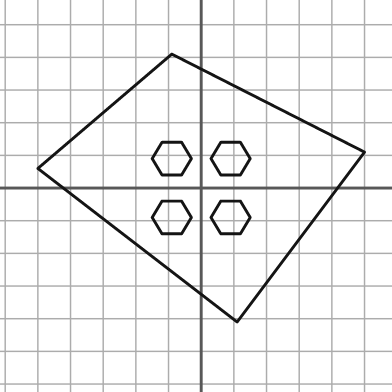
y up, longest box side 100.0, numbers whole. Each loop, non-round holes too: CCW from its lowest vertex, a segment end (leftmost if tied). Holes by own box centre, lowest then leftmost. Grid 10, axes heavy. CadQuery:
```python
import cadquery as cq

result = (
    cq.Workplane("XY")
    .moveTo(11.0, -41.0)
    .lineTo(50.0, 11.0)
    .lineTo(-9.0, 41.0)
    .lineTo(-50.0, 6.0)
    .close()
    .moveTo(-12.0, -14.0)
    .lineTo(-6.0, -14.0)
    .lineTo(-3.0, -9.0)
    .lineTo(-6.0, -4.0)
    .lineTo(-12.0, -4.0)
    .lineTo(-15.0, -9.0)
    .close()
    .moveTo(6.0, -14.0)
    .lineTo(12.0, -14.0)
    .lineTo(15.0, -9.0)
    .lineTo(12.0, -4.0)
    .lineTo(6.0, -4.0)
    .lineTo(3.0, -9.0)
    .close()
    .moveTo(-12.0, 4.0)
    .lineTo(-6.0, 4.0)
    .lineTo(-3.0, 9.0)
    .lineTo(-6.0, 14.0)
    .lineTo(-12.0, 14.0)
    .lineTo(-15.0, 9.0)
    .close()
    .moveTo(6.0, 4.0)
    .lineTo(12.0, 4.0)
    .lineTo(15.0, 9.0)
    .lineTo(12.0, 14.0)
    .lineTo(6.0, 14.0)
    .lineTo(3.0, 9.0)
    .close()
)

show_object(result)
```